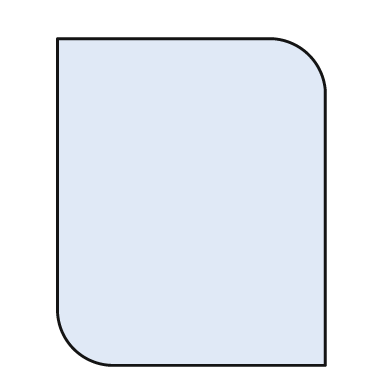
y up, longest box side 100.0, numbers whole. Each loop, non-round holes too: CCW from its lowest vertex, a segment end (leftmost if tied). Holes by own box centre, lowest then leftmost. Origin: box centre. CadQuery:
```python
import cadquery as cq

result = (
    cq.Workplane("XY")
    .moveTo(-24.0, -50.0)
    .lineTo(41.0, -50.0)
    .lineTo(41.0, 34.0)
    .threePointArc((36.0, 45.0), (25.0, 50.0))
    .lineTo(-41.0, 50.0)
    .lineTo(-41.0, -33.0)
    .threePointArc((-36.0, -45.0), (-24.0, -50.0))
    .close()
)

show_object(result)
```